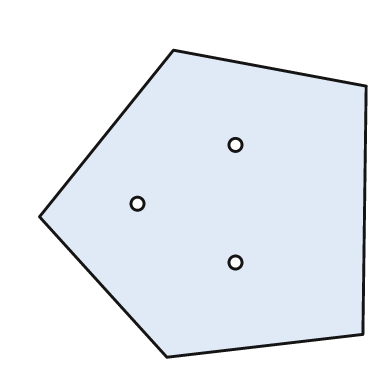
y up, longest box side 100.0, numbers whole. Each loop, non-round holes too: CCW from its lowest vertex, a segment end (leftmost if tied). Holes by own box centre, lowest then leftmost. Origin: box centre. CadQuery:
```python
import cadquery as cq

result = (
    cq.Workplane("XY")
    .moveTo(-11.0, -47.0)
    .lineTo(49.0, -40.0)
    .lineTo(50.0, 36.0)
    .lineTo(-9.0, 47.0)
    .lineTo(-50.0, -4.0)
    .close()
    .moveTo(10.0, -18.0)
    .circle(2.0)
    .moveTo(-20.0, 0.0)
    .circle(2.0)
    .moveTo(10.0, 18.0)
    .circle(2.0)
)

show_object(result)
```